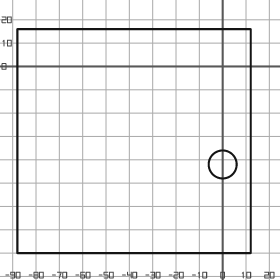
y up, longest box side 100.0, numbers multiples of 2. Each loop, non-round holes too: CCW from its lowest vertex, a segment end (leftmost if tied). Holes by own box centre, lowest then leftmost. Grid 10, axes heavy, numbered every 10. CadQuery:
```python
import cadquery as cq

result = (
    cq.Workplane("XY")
    .moveTo(-88.0, -80.0)
    .lineTo(12.0, -80.0)
    .lineTo(12.0, 16.0)
    .lineTo(-88.0, 16.0)
    .close()
    .moveTo(0.0, -42.0)
    .circle(6.0)
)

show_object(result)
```